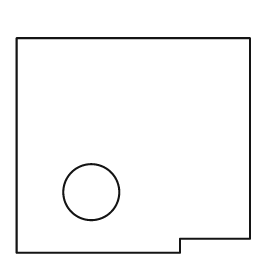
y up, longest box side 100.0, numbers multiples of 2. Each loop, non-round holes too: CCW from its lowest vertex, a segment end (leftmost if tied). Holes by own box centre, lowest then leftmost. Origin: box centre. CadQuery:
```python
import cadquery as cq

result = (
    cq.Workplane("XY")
    .moveTo(-50.0, -46.0)
    .lineTo(20.0, -46.0)
    .lineTo(20.0, -40.0)
    .lineTo(50.0, -40.0)
    .lineTo(50.0, 46.0)
    .lineTo(-50.0, 46.0)
    .close()
    .moveTo(-18.0, -20.0)
    .circle(12.0)
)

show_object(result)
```